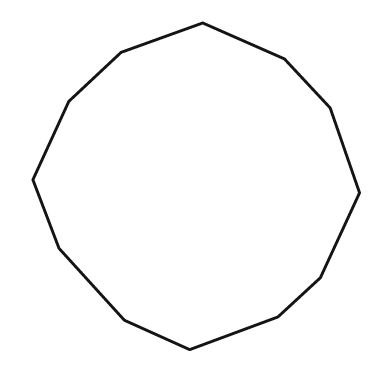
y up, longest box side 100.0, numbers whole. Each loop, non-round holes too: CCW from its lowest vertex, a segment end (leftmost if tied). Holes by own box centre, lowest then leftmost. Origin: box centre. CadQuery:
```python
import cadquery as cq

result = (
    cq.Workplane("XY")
    .moveTo(-2.0, -50.0)
    .lineTo(25.0, -40.0)
    .lineTo(38.0, -28.0)
    .lineTo(50.0, -2.0)
    .lineTo(41.0, 24.0)
    .lineTo(27.0, 39.0)
    .lineTo(2.0, 50.0)
    .lineTo(-23.0, 41.0)
    .lineTo(-39.0, 26.0)
    .lineTo(-50.0, 2.0)
    .lineTo(-42.0, -19.0)
    .lineTo(-22.0, -41.0)
    .close()
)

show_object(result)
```